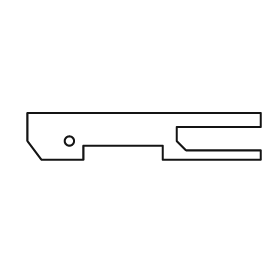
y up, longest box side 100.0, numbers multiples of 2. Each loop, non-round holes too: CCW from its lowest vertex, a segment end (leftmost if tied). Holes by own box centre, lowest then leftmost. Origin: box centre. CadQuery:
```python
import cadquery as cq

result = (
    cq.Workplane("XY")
    .moveTo(-44.0, -10.0)
    .lineTo(-26.0, -10.0)
    .lineTo(-26.0, -4.0)
    .lineTo(8.0, -4.0)
    .lineTo(8.0, -10.0)
    .lineTo(50.0, -10.0)
    .lineTo(50.0, -6.0)
    .lineTo(18.0, -6.0)
    .lineTo(14.0, -2.0)
    .lineTo(14.0, 4.0)
    .lineTo(50.0, 4.0)
    .lineTo(50.0, 10.0)
    .lineTo(-50.0, 10.0)
    .lineTo(-50.0, -2.0)
    .close()
    .moveTo(-32.0, -2.0)
    .circle(2.0)
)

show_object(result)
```